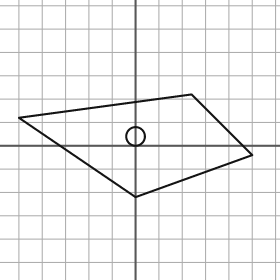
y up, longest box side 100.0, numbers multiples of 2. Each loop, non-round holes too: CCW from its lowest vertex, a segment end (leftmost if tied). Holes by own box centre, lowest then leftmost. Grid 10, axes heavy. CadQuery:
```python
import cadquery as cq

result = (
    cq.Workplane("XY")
    .moveTo(0.0, -22.0)
    .lineTo(50.0, -4.0)
    .lineTo(24.0, 22.0)
    .lineTo(-50.0, 12.0)
    .close()
    .moveTo(0.0, 4.0)
    .circle(4.0)
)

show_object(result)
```